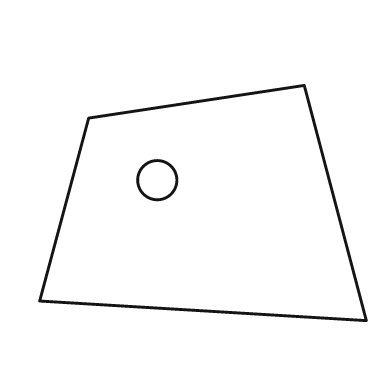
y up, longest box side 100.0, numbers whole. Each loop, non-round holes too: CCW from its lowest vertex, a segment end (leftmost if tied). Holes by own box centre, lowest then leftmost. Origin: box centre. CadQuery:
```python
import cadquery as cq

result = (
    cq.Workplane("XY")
    .moveTo(50.0, -36.0)
    .lineTo(31.0, 36.0)
    .lineTo(-35.0, 26.0)
    .lineTo(-50.0, -30.0)
    .close()
    .moveTo(-14.0, 7.0)
    .circle(6.0)
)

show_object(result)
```